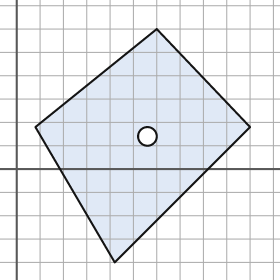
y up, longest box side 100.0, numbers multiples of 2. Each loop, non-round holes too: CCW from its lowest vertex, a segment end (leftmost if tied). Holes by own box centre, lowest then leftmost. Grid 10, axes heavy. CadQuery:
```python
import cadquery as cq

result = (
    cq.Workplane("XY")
    .moveTo(42.0, -40.0)
    .lineTo(100.0, 18.0)
    .lineTo(60.0, 60.0)
    .lineTo(8.0, 18.0)
    .close()
    .moveTo(56.0, 14.0)
    .circle(4.0)
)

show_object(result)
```